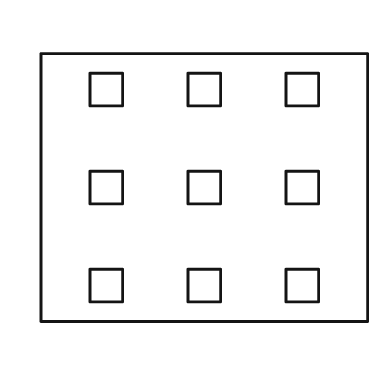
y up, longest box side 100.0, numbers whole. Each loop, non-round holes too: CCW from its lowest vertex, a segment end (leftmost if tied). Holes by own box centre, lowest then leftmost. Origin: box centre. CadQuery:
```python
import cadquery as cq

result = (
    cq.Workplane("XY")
    .moveTo(-50.0, -41.0)
    .lineTo(50.0, -41.0)
    .lineTo(50.0, 41.0)
    .lineTo(-50.0, 41.0)
    .close()
    .moveTo(-35.0, -35.0)
    .lineTo(-25.0, -35.0)
    .lineTo(-25.0, -25.0)
    .lineTo(-35.0, -25.0)
    .close()
    .moveTo(-5.0, -35.0)
    .lineTo(5.0, -35.0)
    .lineTo(5.0, -25.0)
    .lineTo(-5.0, -25.0)
    .close()
    .moveTo(25.0, -35.0)
    .lineTo(35.0, -35.0)
    .lineTo(35.0, -25.0)
    .lineTo(25.0, -25.0)
    .close()
    .moveTo(-35.0, -5.0)
    .lineTo(-25.0, -5.0)
    .lineTo(-25.0, 5.0)
    .lineTo(-35.0, 5.0)
    .close()
    .moveTo(-5.0, -5.0)
    .lineTo(5.0, -5.0)
    .lineTo(5.0, 5.0)
    .lineTo(-5.0, 5.0)
    .close()
    .moveTo(25.0, -5.0)
    .lineTo(35.0, -5.0)
    .lineTo(35.0, 5.0)
    .lineTo(25.0, 5.0)
    .close()
    .moveTo(-35.0, 25.0)
    .lineTo(-25.0, 25.0)
    .lineTo(-25.0, 35.0)
    .lineTo(-35.0, 35.0)
    .close()
    .moveTo(-5.0, 25.0)
    .lineTo(5.0, 25.0)
    .lineTo(5.0, 35.0)
    .lineTo(-5.0, 35.0)
    .close()
    .moveTo(25.0, 25.0)
    .lineTo(35.0, 25.0)
    .lineTo(35.0, 35.0)
    .lineTo(25.0, 35.0)
    .close()
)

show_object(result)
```